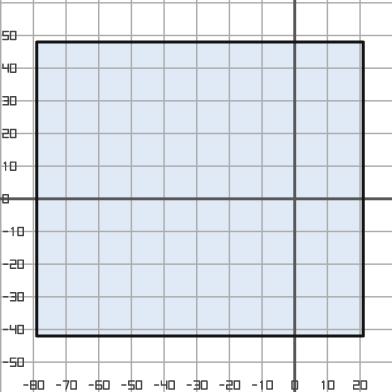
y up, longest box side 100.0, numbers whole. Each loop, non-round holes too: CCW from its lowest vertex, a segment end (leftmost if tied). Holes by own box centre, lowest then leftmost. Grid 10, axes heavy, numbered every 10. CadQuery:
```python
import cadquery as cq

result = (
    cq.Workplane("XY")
    .moveTo(-79.0, -42.0)
    .lineTo(21.0, -42.0)
    .lineTo(21.0, 48.0)
    .lineTo(-79.0, 48.0)
    .close()
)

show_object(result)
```